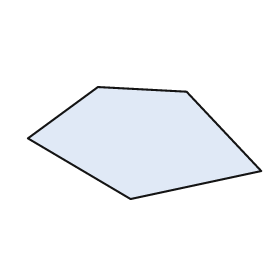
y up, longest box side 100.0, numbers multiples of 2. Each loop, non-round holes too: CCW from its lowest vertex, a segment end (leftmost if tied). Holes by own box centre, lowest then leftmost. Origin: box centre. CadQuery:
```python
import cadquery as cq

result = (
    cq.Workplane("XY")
    .moveTo(-6.0, -24.0)
    .lineTo(50.0, -12.0)
    .lineTo(18.0, 22.0)
    .lineTo(-20.0, 24.0)
    .lineTo(-50.0, 2.0)
    .close()
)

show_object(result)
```